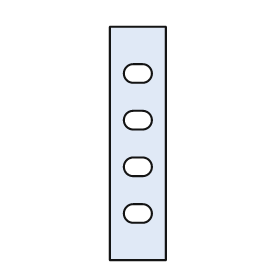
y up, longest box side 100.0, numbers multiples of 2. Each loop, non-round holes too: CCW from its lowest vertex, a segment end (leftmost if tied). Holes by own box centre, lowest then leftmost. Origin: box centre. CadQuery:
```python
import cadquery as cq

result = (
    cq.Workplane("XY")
    .moveTo(-12.0, -50.0)
    .lineTo(12.0, -50.0)
    .lineTo(12.0, 50.0)
    .lineTo(-12.0, 50.0)
    .close()
    .moveTo(-2.0, -34.0)
    .lineTo(2.0, -34.0)
    .threePointArc((6.0, -30.0), (2.0, -26.0))
    .lineTo(-2.0, -26.0)
    .threePointArc((-6.0, -30.0), (-2.0, -34.0))
    .close()
    .moveTo(-2.0, -14.0)
    .lineTo(2.0, -14.0)
    .threePointArc((6.0, -10.0), (2.0, -6.0))
    .lineTo(-2.0, -6.0)
    .threePointArc((-6.0, -10.0), (-2.0, -14.0))
    .close()
    .moveTo(-2.0, 6.0)
    .lineTo(2.0, 6.0)
    .threePointArc((6.0, 10.0), (2.0, 14.0))
    .lineTo(-2.0, 14.0)
    .threePointArc((-6.0, 10.0), (-2.0, 6.0))
    .close()
    .moveTo(-2.0, 26.0)
    .lineTo(2.0, 26.0)
    .threePointArc((6.0, 30.0), (2.0, 34.0))
    .lineTo(-2.0, 34.0)
    .threePointArc((-6.0, 30.0), (-2.0, 26.0))
    .close()
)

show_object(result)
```